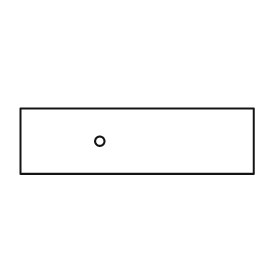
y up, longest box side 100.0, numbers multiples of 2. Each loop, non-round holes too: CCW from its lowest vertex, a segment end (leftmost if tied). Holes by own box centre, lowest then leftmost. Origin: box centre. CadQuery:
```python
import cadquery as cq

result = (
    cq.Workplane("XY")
    .moveTo(-50.0, -14.0)
    .lineTo(50.0, -14.0)
    .lineTo(50.0, 14.0)
    .lineTo(-50.0, 14.0)
    .close()
    .moveTo(-16.0, 0.0)
    .circle(2.0)
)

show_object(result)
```